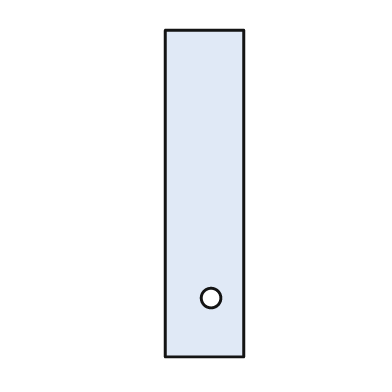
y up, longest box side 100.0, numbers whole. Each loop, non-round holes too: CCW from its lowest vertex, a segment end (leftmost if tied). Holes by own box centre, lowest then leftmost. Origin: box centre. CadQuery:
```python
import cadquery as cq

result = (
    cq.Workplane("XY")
    .moveTo(-12.0, -50.0)
    .lineTo(12.0, -50.0)
    .lineTo(12.0, 50.0)
    .lineTo(-12.0, 50.0)
    .close()
    .moveTo(2.0, -32.0)
    .circle(3.0)
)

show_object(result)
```